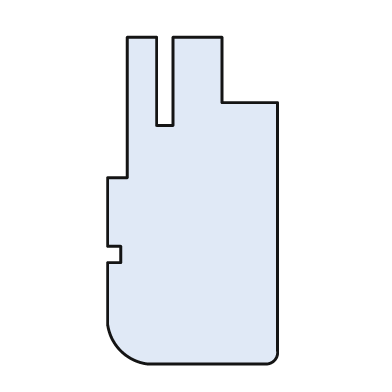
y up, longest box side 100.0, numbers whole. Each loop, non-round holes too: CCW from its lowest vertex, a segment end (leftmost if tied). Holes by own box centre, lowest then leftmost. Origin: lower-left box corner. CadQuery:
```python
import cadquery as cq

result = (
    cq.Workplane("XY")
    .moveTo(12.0, 0.0)
    .lineTo(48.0, 0.0)
    .threePointArc((51.0, 1.0), (52.0, 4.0))
    .lineTo(52.0, 80.0)
    .lineTo(35.0, 80.0)
    .lineTo(35.0, 100.0)
    .lineTo(20.0, 100.0)
    .lineTo(20.0, 73.0)
    .lineTo(15.0, 73.0)
    .lineTo(15.0, 100.0)
    .lineTo(6.0, 100.0)
    .lineTo(6.0, 57.0)
    .lineTo(0.0, 57.0)
    .lineTo(0.0, 36.0)
    .lineTo(4.0, 36.0)
    .lineTo(4.0, 31.0)
    .lineTo(0.0, 31.0)
    .lineTo(0.0, 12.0)
    .threePointArc((4.0, 4.0), (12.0, 0.0))
    .close()
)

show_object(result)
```